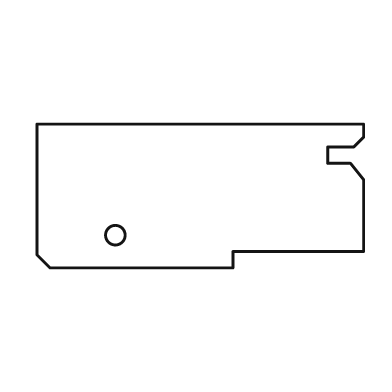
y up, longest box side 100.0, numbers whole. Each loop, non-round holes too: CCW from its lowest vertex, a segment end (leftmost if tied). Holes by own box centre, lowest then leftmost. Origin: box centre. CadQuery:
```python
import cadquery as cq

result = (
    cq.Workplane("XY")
    .moveTo(-46.0, -22.0)
    .lineTo(10.0, -22.0)
    .lineTo(10.0, -17.0)
    .lineTo(50.0, -17.0)
    .lineTo(50.0, 5.0)
    .lineTo(46.0, 10.0)
    .lineTo(39.0, 10.0)
    .lineTo(39.0, 15.0)
    .lineTo(47.0, 15.0)
    .lineTo(50.0, 18.0)
    .lineTo(50.0, 22.0)
    .lineTo(-50.0, 22.0)
    .lineTo(-50.0, -18.0)
    .close()
    .moveTo(-26.0, -12.0)
    .circle(3.0)
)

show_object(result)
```